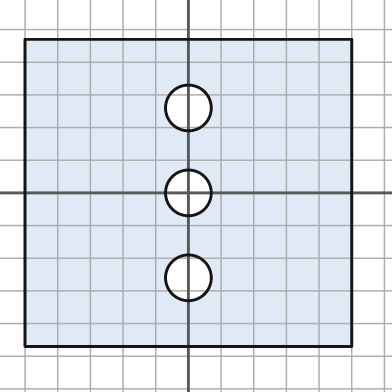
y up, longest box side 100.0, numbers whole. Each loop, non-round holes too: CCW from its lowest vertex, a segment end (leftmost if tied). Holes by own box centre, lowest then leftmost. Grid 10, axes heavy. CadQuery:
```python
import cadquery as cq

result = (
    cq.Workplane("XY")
    .moveTo(-50.0, -47.0)
    .lineTo(50.0, -47.0)
    .lineTo(50.0, 47.0)
    .lineTo(-50.0, 47.0)
    .close()
    .moveTo(0.0, -26.0)
    .circle(7.0)
    .moveTo(0.0, 0.0)
    .circle(7.0)
    .moveTo(0.0, 26.0)
    .circle(7.0)
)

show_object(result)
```